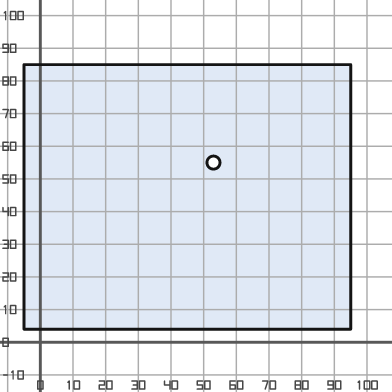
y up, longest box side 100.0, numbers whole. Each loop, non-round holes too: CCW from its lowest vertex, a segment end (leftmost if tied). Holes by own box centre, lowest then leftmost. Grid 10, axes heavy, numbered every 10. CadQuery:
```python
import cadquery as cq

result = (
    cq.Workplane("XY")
    .moveTo(-5.0, 4.0)
    .lineTo(95.0, 4.0)
    .lineTo(95.0, 85.0)
    .lineTo(-5.0, 85.0)
    .close()
    .moveTo(53.0, 55.0)
    .circle(2.0)
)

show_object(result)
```